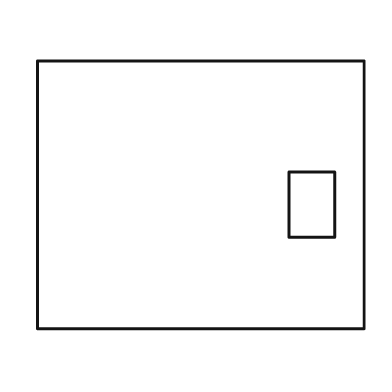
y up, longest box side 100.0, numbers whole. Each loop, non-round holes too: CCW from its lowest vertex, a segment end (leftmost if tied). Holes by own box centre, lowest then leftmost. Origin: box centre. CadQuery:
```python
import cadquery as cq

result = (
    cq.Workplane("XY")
    .moveTo(-50.0, -41.0)
    .lineTo(50.0, -41.0)
    .lineTo(50.0, 41.0)
    .lineTo(-50.0, 41.0)
    .close()
    .moveTo(27.0, -13.0)
    .lineTo(41.0, -13.0)
    .lineTo(41.0, 7.0)
    .lineTo(27.0, 7.0)
    .close()
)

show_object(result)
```